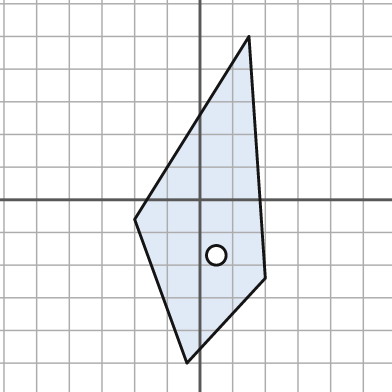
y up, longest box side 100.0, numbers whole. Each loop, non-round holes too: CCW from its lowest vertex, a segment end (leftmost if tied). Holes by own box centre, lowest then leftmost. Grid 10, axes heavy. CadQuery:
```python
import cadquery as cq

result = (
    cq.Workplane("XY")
    .moveTo(-4.0, -50.0)
    .lineTo(20.0, -24.0)
    .lineTo(15.0, 50.0)
    .lineTo(-20.0, -6.0)
    .close()
    .moveTo(5.0, -17.0)
    .circle(3.0)
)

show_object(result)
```